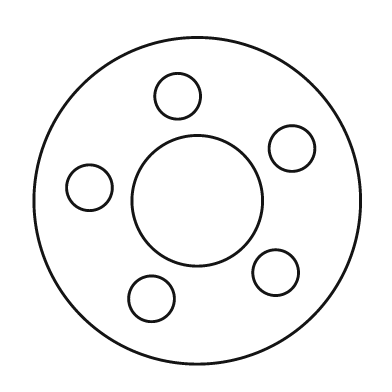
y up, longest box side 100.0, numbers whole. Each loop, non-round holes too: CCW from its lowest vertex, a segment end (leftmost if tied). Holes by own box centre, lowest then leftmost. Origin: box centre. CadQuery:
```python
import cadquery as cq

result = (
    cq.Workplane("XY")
    .moveTo(0.0, 0.0)
    .circle(50.0)
    .moveTo(-14.0, -30.0)
    .circle(7.0)
    .moveTo(24.0, -22.0)
    .circle(7.0)
    .moveTo(0.0, 0.0)
    .circle(20.0)
    .moveTo(-33.0, 4.0)
    .circle(7.0)
    .moveTo(29.0, 16.0)
    .circle(7.0)
    .moveTo(-6.0, 32.0)
    .circle(7.0)
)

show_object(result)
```